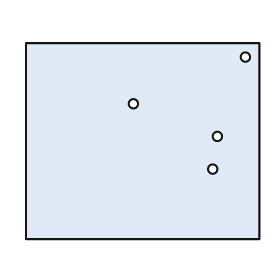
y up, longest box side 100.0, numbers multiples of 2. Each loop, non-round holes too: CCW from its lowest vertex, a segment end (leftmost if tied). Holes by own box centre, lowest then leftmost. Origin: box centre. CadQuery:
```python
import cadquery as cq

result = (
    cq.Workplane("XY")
    .moveTo(-50.0, -42.0)
    .lineTo(50.0, -42.0)
    .lineTo(50.0, 42.0)
    .lineTo(-50.0, 42.0)
    .close()
    .moveTo(30.0, -12.0)
    .circle(2.0)
    .moveTo(32.0, 2.0)
    .circle(2.0)
    .moveTo(-4.0, 16.0)
    .circle(2.0)
    .moveTo(44.0, 36.0)
    .circle(2.0)
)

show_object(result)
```